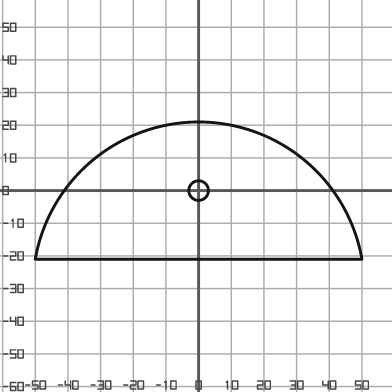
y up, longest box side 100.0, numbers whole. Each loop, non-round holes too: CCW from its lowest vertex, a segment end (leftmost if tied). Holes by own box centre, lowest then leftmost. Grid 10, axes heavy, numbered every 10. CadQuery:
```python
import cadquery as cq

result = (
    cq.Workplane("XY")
    .moveTo(-50.0, -21.0)
    .lineTo(50.0, -21.0)
    .threePointArc((0.0, 21.0), (-50.0, -21.0))
    .close()
    .moveTo(0.0, 0.0)
    .circle(3.0)
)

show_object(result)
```